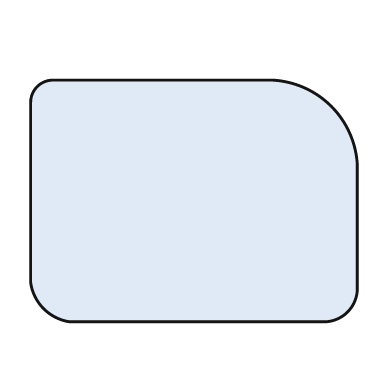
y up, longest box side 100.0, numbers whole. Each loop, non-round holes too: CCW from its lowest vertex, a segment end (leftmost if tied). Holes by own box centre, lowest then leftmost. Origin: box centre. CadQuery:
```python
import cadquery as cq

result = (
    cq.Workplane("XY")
    .moveTo(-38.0, -37.0)
    .lineTo(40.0, -37.0)
    .threePointArc((47.0, -34.0), (50.0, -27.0))
    .lineTo(50.0, 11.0)
    .threePointArc((42.0, 29.0), (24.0, 37.0))
    .lineTo(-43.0, 37.0)
    .threePointArc((-48.0, 35.0), (-50.0, 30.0))
    .lineTo(-50.0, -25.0)
    .threePointArc((-46.0, -33.0), (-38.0, -37.0))
    .close()
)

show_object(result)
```